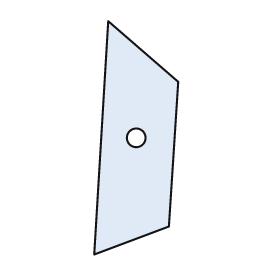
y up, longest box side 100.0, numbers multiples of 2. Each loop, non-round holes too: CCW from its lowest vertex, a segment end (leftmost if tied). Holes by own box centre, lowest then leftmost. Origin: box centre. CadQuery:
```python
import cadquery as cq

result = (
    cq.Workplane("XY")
    .moveTo(-18.0, -50.0)
    .lineTo(14.0, -38.0)
    .lineTo(18.0, 24.0)
    .lineTo(-12.0, 50.0)
    .close()
    .moveTo(0.0, 0.0)
    .circle(4.0)
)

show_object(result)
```